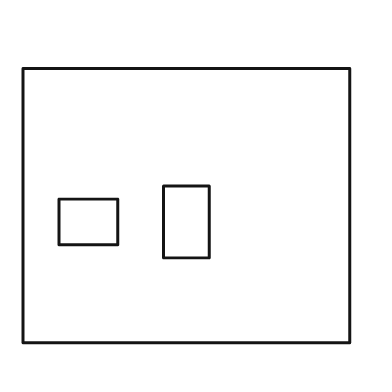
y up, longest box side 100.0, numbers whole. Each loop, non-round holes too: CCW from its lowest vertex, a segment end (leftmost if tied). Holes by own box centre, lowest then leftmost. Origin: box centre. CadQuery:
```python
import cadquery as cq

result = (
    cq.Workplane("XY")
    .moveTo(-50.0, -42.0)
    .lineTo(50.0, -42.0)
    .lineTo(50.0, 42.0)
    .lineTo(-50.0, 42.0)
    .close()
    .moveTo(-39.0, -12.0)
    .lineTo(-21.0, -12.0)
    .lineTo(-21.0, 2.0)
    .lineTo(-39.0, 2.0)
    .close()
    .moveTo(-7.0, -16.0)
    .lineTo(7.0, -16.0)
    .lineTo(7.0, 6.0)
    .lineTo(-7.0, 6.0)
    .close()
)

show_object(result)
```